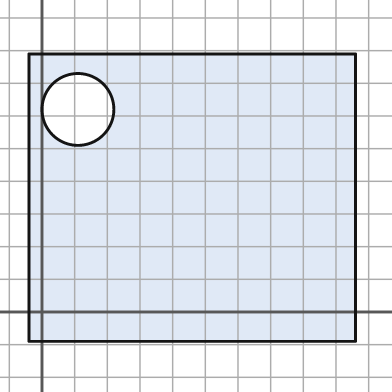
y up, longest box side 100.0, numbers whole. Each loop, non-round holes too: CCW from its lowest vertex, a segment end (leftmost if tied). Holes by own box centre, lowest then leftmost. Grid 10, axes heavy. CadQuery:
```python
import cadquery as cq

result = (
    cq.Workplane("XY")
    .moveTo(-4.0, -9.0)
    .lineTo(96.0, -9.0)
    .lineTo(96.0, 79.0)
    .lineTo(-4.0, 79.0)
    .close()
    .moveTo(11.0, 62.0)
    .circle(11.0)
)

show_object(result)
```